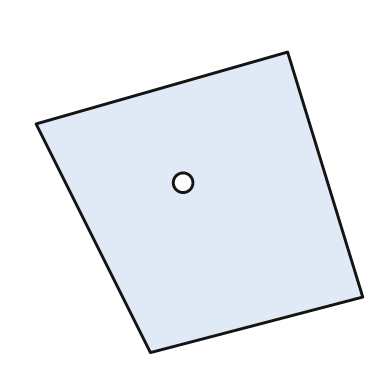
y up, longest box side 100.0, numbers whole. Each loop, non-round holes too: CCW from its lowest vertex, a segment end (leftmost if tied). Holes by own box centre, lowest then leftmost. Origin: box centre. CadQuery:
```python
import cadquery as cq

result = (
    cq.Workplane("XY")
    .moveTo(-15.0, -46.0)
    .lineTo(50.0, -29.0)
    .lineTo(27.0, 46.0)
    .lineTo(-50.0, 24.0)
    .close()
    .moveTo(-5.0, 6.0)
    .circle(3.0)
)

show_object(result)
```